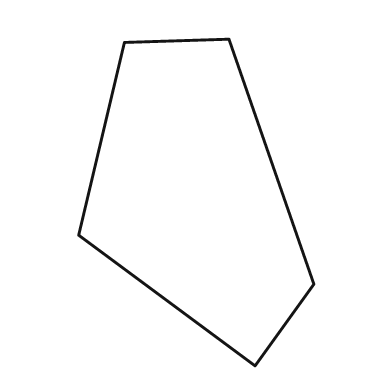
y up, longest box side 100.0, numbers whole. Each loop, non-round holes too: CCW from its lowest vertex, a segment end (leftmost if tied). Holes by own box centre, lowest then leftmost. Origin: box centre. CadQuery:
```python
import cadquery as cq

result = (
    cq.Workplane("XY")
    .moveTo(18.0, -50.0)
    .lineTo(36.0, -25.0)
    .lineTo(10.0, 50.0)
    .lineTo(-22.0, 49.0)
    .lineTo(-36.0, -10.0)
    .close()
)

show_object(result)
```